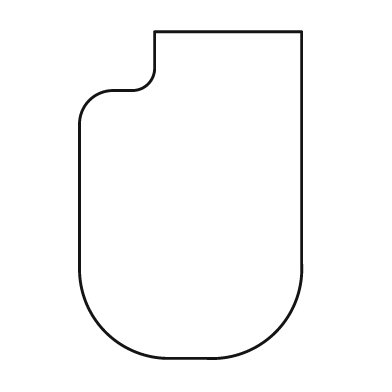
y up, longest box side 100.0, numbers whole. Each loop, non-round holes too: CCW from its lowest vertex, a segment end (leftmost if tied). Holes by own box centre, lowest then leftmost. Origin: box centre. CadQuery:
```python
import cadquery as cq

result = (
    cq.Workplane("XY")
    .moveTo(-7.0, -50.0)
    .lineTo(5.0, -50.0)
    .threePointArc((26.0, -42.0), (34.0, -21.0))
    .lineTo(34.0, 50.0)
    .lineTo(-11.0, 50.0)
    .lineTo(-11.0, 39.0)
    .threePointArc((-13.0, 34.0), (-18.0, 32.0))
    .lineTo(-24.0, 32.0)
    .threePointArc((-31.0, 29.0), (-34.0, 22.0))
    .lineTo(-34.0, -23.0)
    .threePointArc((-26.0, -42.0), (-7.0, -50.0))
    .close()
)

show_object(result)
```